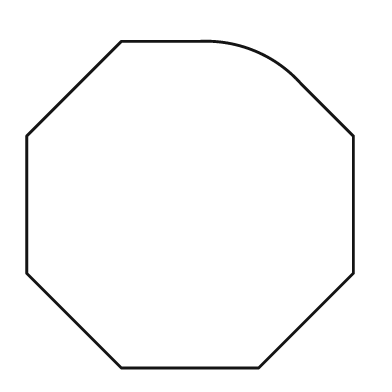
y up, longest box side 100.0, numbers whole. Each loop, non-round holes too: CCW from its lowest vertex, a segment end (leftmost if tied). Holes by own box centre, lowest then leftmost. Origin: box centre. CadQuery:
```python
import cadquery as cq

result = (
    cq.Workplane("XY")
    .moveTo(-21.0, -50.0)
    .lineTo(21.0, -50.0)
    .lineTo(50.0, -21.0)
    .lineTo(50.0, 21.0)
    .lineTo(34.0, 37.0)
    .threePointArc((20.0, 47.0), (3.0, 50.0))
    .lineTo(-21.0, 50.0)
    .lineTo(-50.0, 21.0)
    .lineTo(-50.0, -21.0)
    .close()
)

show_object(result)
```